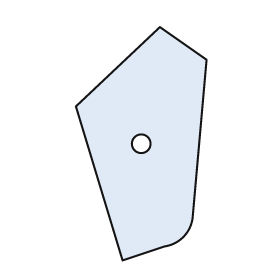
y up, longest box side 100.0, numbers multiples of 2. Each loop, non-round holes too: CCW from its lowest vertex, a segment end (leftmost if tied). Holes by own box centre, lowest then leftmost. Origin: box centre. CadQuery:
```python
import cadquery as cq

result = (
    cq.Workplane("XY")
    .moveTo(-8.0, -50.0)
    .lineTo(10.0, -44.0)
    .threePointArc((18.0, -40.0), (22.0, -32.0))
    .lineTo(28.0, 36.0)
    .lineTo(8.0, 50.0)
    .lineTo(-28.0, 16.0)
    .close()
    .moveTo(0.0, 0.0)
    .circle(4.0)
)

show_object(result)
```